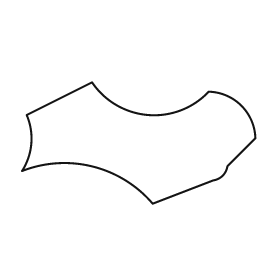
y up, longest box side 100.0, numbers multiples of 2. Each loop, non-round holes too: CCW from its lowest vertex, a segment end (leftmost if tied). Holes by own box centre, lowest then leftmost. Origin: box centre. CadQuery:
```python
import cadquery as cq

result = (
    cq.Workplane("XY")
    .moveTo(6.0, -26.0)
    .lineTo(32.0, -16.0)
    .threePointArc((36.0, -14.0), (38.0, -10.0))
    .lineTo(50.0, 2.0)
    .threePointArc((44.0, 16.0), (30.0, 22.0))
    .threePointArc((4.0, 12.0), (-20.0, 26.0))
    .lineTo(-48.0, 12.0)
    .threePointArc((-46.0, 0.0), (-50.0, -12.0))
    .threePointArc((-20.0, -10.0), (6.0, -26.0))
    .close()
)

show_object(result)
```